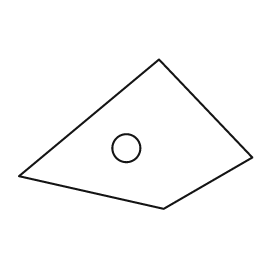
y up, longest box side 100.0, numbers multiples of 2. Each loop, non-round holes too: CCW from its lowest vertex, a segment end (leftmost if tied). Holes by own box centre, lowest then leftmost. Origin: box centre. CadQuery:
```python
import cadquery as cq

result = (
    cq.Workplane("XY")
    .moveTo(12.0, -32.0)
    .lineTo(50.0, -10.0)
    .lineTo(10.0, 32.0)
    .lineTo(-50.0, -18.0)
    .close()
    .moveTo(-4.0, -6.0)
    .circle(6.0)
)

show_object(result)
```